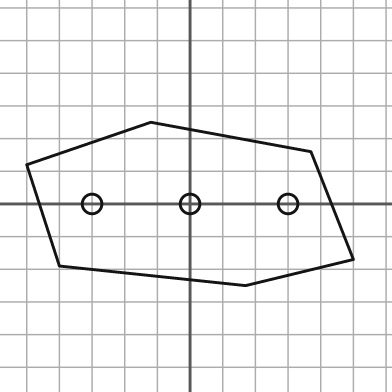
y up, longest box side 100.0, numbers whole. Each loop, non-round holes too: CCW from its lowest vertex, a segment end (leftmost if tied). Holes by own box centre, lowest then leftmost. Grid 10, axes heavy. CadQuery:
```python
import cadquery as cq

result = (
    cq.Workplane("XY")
    .moveTo(17.0, -25.0)
    .lineTo(50.0, -17.0)
    .lineTo(37.0, 16.0)
    .lineTo(-12.0, 25.0)
    .lineTo(-50.0, 12.0)
    .lineTo(-40.0, -19.0)
    .close()
    .moveTo(-30.0, 0.0)
    .circle(3.0)
    .moveTo(0.0, 0.0)
    .circle(3.0)
    .moveTo(30.0, 0.0)
    .circle(3.0)
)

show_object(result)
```